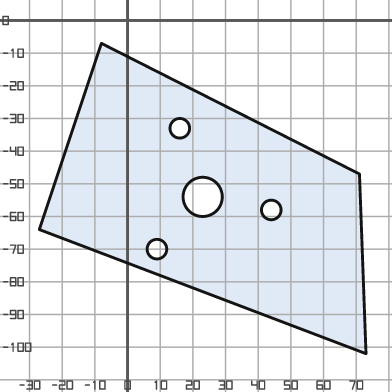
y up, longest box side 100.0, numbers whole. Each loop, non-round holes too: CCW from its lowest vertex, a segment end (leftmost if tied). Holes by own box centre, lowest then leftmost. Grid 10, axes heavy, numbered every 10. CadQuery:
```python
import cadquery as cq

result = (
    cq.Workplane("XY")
    .moveTo(73.0, -102.0)
    .lineTo(71.0, -47.0)
    .lineTo(-8.0, -7.0)
    .lineTo(-27.0, -64.0)
    .close()
    .moveTo(9.0, -70.0)
    .circle(3.0)
    .moveTo(44.0, -58.0)
    .circle(3.0)
    .moveTo(23.0, -54.0)
    .circle(6.0)
    .moveTo(16.0, -33.0)
    .circle(3.0)
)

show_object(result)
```